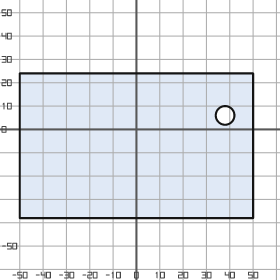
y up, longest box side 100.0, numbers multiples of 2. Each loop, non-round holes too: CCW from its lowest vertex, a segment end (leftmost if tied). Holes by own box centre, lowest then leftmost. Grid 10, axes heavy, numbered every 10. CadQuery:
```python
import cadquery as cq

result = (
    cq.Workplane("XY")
    .moveTo(-50.0, -38.0)
    .lineTo(50.0, -38.0)
    .lineTo(50.0, 24.0)
    .lineTo(-50.0, 24.0)
    .close()
    .moveTo(38.0, 6.0)
    .circle(4.0)
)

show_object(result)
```